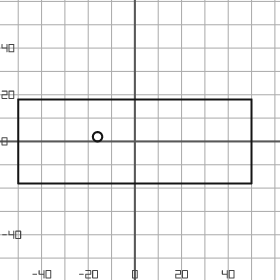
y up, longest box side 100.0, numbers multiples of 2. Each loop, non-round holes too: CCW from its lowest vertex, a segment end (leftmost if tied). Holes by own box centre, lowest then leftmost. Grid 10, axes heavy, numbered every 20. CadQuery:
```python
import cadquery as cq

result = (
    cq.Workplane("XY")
    .moveTo(-50.0, -18.0)
    .lineTo(50.0, -18.0)
    .lineTo(50.0, 18.0)
    .lineTo(-50.0, 18.0)
    .close()
    .moveTo(-16.0, 2.0)
    .circle(2.0)
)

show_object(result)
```